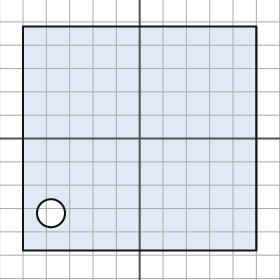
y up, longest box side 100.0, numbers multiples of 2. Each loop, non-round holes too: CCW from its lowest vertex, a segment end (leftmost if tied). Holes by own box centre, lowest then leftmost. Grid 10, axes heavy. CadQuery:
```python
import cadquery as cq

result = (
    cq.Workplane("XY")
    .moveTo(-50.0, -48.0)
    .lineTo(50.0, -48.0)
    .lineTo(50.0, 48.0)
    .lineTo(-50.0, 48.0)
    .close()
    .moveTo(-38.0, -32.0)
    .circle(6.0)
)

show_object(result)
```